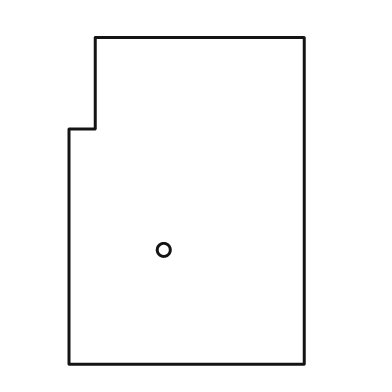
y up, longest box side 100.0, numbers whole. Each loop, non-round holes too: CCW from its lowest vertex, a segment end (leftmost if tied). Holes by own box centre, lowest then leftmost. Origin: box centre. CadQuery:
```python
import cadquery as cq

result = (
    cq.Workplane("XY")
    .moveTo(-36.0, -50.0)
    .lineTo(36.0, -50.0)
    .lineTo(36.0, 50.0)
    .lineTo(-28.0, 50.0)
    .lineTo(-28.0, 22.0)
    .lineTo(-36.0, 22.0)
    .close()
    .moveTo(-7.0, -15.0)
    .circle(2.0)
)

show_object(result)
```